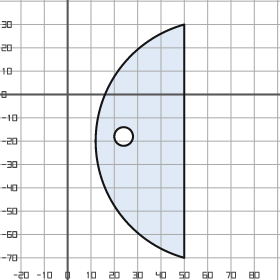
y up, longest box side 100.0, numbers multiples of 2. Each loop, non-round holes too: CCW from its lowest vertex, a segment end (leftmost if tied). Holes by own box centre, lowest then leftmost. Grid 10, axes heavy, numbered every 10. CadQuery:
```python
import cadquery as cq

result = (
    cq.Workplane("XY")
    .moveTo(50.0, -70.0)
    .lineTo(50.0, 30.0)
    .threePointArc((12.0, -20.0), (50.0, -70.0))
    .close()
    .moveTo(24.0, -18.0)
    .circle(4.0)
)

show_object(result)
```